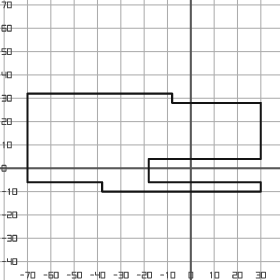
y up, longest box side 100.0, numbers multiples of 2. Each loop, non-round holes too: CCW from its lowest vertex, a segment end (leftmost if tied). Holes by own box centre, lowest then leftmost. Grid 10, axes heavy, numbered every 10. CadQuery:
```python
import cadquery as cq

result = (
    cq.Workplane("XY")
    .moveTo(-38.0, -10.0)
    .lineTo(30.0, -10.0)
    .lineTo(30.0, -6.0)
    .lineTo(-18.0, -6.0)
    .lineTo(-18.0, 4.0)
    .lineTo(30.0, 4.0)
    .lineTo(30.0, 28.0)
    .lineTo(-8.0, 28.0)
    .lineTo(-8.0, 32.0)
    .lineTo(-70.0, 32.0)
    .lineTo(-70.0, -6.0)
    .lineTo(-38.0, -6.0)
    .close()
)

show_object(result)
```